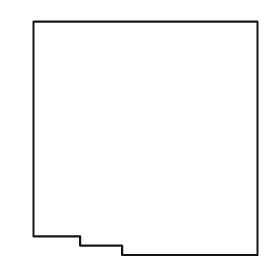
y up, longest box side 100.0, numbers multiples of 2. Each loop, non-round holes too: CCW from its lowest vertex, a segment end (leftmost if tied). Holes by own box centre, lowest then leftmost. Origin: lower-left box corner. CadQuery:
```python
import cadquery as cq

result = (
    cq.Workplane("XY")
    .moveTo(38.0, 0.0)
    .lineTo(96.0, 0.0)
    .lineTo(96.0, 100.0)
    .lineTo(0.0, 100.0)
    .lineTo(0.0, 8.0)
    .lineTo(20.0, 8.0)
    .lineTo(20.0, 4.0)
    .lineTo(38.0, 4.0)
    .close()
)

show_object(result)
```